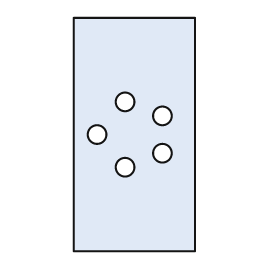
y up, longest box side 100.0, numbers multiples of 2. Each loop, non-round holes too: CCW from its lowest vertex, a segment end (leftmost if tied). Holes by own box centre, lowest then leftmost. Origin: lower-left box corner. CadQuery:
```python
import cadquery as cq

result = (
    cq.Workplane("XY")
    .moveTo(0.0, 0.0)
    .lineTo(52.0, 0.0)
    .lineTo(52.0, 100.0)
    .lineTo(0.0, 100.0)
    .close()
    .moveTo(22.0, 36.0)
    .circle(4.0)
    .moveTo(38.0, 42.0)
    .circle(4.0)
    .moveTo(10.0, 50.0)
    .circle(4.0)
    .moveTo(38.0, 58.0)
    .circle(4.0)
    .moveTo(22.0, 64.0)
    .circle(4.0)
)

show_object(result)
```